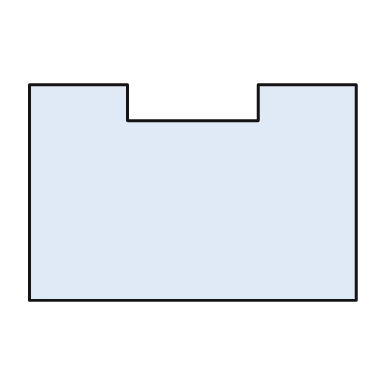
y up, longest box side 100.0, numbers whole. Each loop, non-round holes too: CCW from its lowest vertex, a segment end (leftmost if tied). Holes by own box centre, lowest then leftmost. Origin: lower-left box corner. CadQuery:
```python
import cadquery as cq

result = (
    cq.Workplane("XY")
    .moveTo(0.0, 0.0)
    .lineTo(100.0, 0.0)
    .lineTo(100.0, 66.0)
    .lineTo(70.0, 66.0)
    .lineTo(70.0, 55.0)
    .lineTo(30.0, 55.0)
    .lineTo(30.0, 66.0)
    .lineTo(0.0, 66.0)
    .close()
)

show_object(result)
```